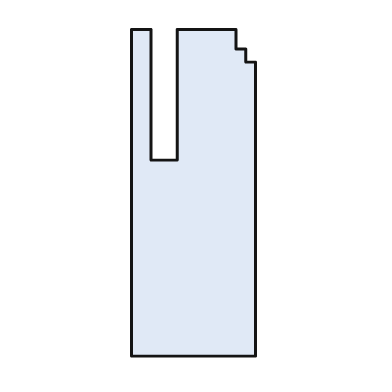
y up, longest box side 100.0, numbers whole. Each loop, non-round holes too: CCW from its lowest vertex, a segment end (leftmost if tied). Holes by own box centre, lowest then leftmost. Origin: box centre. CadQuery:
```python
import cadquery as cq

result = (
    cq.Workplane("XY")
    .moveTo(-19.0, -50.0)
    .lineTo(19.0, -50.0)
    .lineTo(19.0, 40.0)
    .lineTo(16.0, 40.0)
    .lineTo(16.0, 44.0)
    .lineTo(13.0, 44.0)
    .lineTo(13.0, 50.0)
    .lineTo(-5.0, 50.0)
    .lineTo(-5.0, 10.0)
    .lineTo(-13.0, 10.0)
    .lineTo(-13.0, 50.0)
    .lineTo(-19.0, 50.0)
    .close()
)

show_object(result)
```